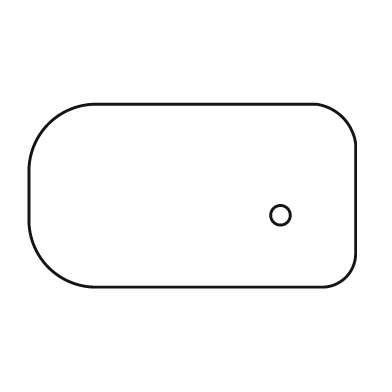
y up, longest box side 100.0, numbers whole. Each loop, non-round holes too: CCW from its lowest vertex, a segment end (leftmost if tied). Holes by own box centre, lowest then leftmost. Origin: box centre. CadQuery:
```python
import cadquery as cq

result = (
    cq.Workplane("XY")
    .moveTo(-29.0, -28.0)
    .lineTo(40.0, -28.0)
    .threePointArc((47.0, -25.0), (50.0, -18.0))
    .lineTo(50.0, 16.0)
    .threePointArc((46.0, 24.0), (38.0, 28.0))
    .lineTo(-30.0, 28.0)
    .threePointArc((-44.0, 22.0), (-50.0, 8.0))
    .lineTo(-50.0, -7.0)
    .threePointArc((-44.0, -22.0), (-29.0, -28.0))
    .close()
    .moveTo(27.0, -6.0)
    .circle(3.0)
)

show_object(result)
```